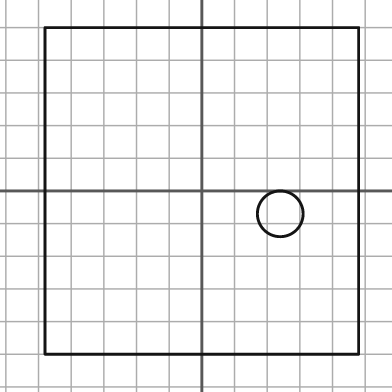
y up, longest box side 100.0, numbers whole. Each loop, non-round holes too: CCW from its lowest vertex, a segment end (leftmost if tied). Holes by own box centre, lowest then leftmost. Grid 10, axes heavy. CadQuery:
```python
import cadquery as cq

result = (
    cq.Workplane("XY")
    .moveTo(-48.0, -50.0)
    .lineTo(48.0, -50.0)
    .lineTo(48.0, 50.0)
    .lineTo(-48.0, 50.0)
    .close()
    .moveTo(24.0, -7.0)
    .circle(7.0)
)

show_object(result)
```